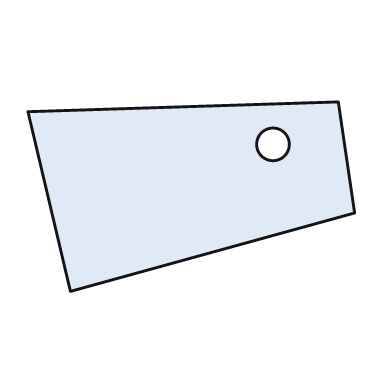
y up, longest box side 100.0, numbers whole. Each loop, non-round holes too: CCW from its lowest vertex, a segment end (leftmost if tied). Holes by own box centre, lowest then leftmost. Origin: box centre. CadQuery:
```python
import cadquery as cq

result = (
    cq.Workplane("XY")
    .moveTo(-37.0, -29.0)
    .lineTo(50.0, -5.0)
    .lineTo(45.0, 29.0)
    .lineTo(-50.0, 26.0)
    .close()
    .moveTo(25.0, 16.0)
    .circle(5.0)
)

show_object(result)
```